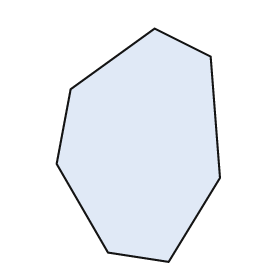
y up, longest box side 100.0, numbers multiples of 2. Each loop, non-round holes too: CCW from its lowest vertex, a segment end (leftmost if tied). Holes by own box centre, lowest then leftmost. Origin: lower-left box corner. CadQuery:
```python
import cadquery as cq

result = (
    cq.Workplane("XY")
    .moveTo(48.0, 0.0)
    .lineTo(70.0, 36.0)
    .lineTo(66.0, 88.0)
    .lineTo(42.0, 100.0)
    .lineTo(6.0, 74.0)
    .lineTo(0.0, 42.0)
    .lineTo(22.0, 4.0)
    .close()
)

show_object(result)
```